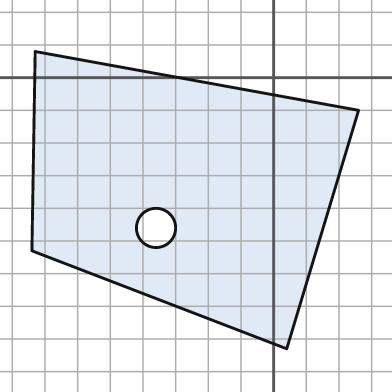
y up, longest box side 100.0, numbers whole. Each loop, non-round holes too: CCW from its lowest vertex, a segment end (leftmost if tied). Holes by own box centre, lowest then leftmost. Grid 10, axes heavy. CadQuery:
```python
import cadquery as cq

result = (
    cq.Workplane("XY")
    .moveTo(4.0, -83.0)
    .lineTo(26.0, -10.0)
    .lineTo(-73.0, 8.0)
    .lineTo(-74.0, -53.0)
    .close()
    .moveTo(-36.0, -46.0)
    .circle(6.0)
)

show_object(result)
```